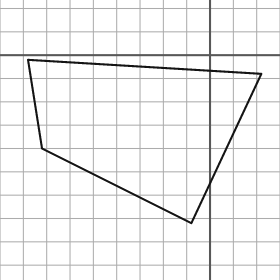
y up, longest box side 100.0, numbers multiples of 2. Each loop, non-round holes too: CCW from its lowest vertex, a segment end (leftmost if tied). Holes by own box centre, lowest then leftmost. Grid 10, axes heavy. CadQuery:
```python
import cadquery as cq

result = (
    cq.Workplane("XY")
    .moveTo(-8.0, -72.0)
    .lineTo(22.0, -8.0)
    .lineTo(-78.0, -2.0)
    .lineTo(-72.0, -40.0)
    .close()
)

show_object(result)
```